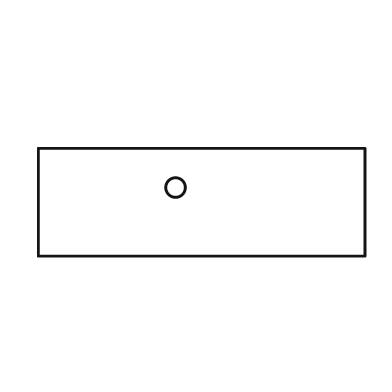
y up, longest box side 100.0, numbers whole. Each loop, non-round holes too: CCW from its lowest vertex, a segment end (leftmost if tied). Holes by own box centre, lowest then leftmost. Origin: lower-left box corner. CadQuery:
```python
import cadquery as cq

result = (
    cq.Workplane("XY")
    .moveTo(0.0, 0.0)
    .lineTo(100.0, 0.0)
    .lineTo(100.0, 33.0)
    .lineTo(0.0, 33.0)
    .close()
    .moveTo(42.0, 21.0)
    .circle(3.0)
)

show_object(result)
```